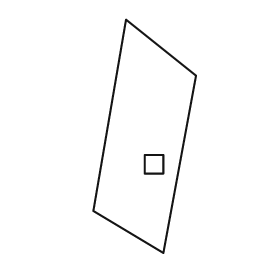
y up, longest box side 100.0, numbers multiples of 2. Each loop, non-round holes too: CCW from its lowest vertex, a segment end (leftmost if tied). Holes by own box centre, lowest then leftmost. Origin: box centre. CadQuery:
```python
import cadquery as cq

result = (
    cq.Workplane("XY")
    .moveTo(8.0, -50.0)
    .lineTo(22.0, 26.0)
    .lineTo(-8.0, 50.0)
    .lineTo(-22.0, -32.0)
    .close()
    .moveTo(0.0, -16.0)
    .lineTo(8.0, -16.0)
    .lineTo(8.0, -8.0)
    .lineTo(0.0, -8.0)
    .close()
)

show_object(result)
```